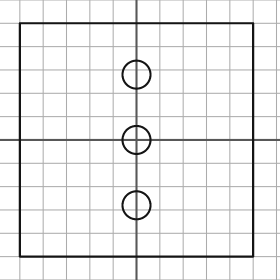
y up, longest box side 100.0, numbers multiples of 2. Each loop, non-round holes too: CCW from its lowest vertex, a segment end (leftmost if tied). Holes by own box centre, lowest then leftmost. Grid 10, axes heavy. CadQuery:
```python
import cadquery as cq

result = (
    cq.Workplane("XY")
    .moveTo(-50.0, -50.0)
    .lineTo(50.0, -50.0)
    .lineTo(50.0, 50.0)
    .lineTo(-50.0, 50.0)
    .close()
    .moveTo(0.0, -28.0)
    .circle(6.0)
    .moveTo(0.0, 0.0)
    .circle(6.0)
    .moveTo(0.0, 28.0)
    .circle(6.0)
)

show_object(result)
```